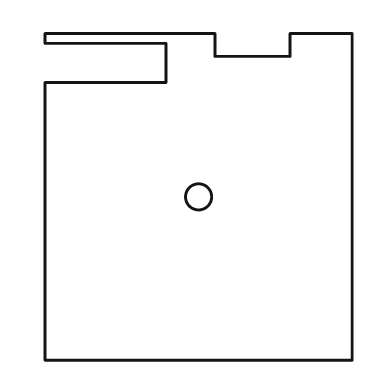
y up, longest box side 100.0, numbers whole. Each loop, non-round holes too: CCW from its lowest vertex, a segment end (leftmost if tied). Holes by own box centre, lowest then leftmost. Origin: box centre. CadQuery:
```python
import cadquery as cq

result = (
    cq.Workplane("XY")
    .moveTo(-47.0, -50.0)
    .lineTo(47.0, -50.0)
    .lineTo(47.0, 50.0)
    .lineTo(28.0, 50.0)
    .lineTo(28.0, 43.0)
    .lineTo(5.0, 43.0)
    .lineTo(5.0, 50.0)
    .lineTo(-47.0, 50.0)
    .lineTo(-47.0, 47.0)
    .lineTo(-10.0, 47.0)
    .lineTo(-10.0, 35.0)
    .lineTo(-47.0, 35.0)
    .close()
    .moveTo(0.0, 0.0)
    .circle(4.0)
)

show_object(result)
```